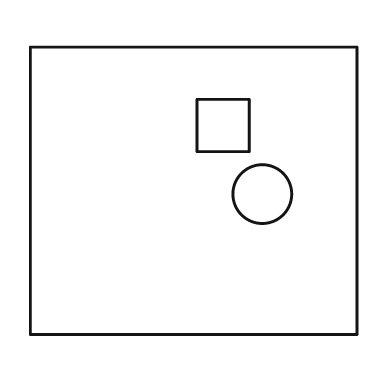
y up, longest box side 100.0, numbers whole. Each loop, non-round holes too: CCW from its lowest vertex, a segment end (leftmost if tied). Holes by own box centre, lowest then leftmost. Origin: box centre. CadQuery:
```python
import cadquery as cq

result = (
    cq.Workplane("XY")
    .moveTo(-50.0, -44.0)
    .lineTo(50.0, -44.0)
    .lineTo(50.0, 44.0)
    .lineTo(-50.0, 44.0)
    .close()
    .moveTo(21.0, -1.0)
    .circle(9.0)
    .moveTo(1.0, 12.0)
    .lineTo(17.0, 12.0)
    .lineTo(17.0, 28.0)
    .lineTo(1.0, 28.0)
    .close()
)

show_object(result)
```